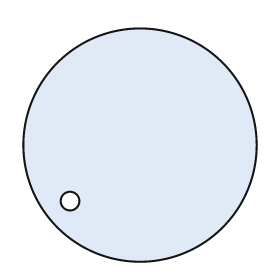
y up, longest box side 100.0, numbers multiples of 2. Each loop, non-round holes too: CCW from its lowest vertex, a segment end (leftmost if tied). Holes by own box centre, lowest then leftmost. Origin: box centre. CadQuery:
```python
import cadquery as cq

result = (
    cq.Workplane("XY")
    .moveTo(0.0, 0.0)
    .circle(50.0)
    .moveTo(-30.0, -24.0)
    .circle(4.0)
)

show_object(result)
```